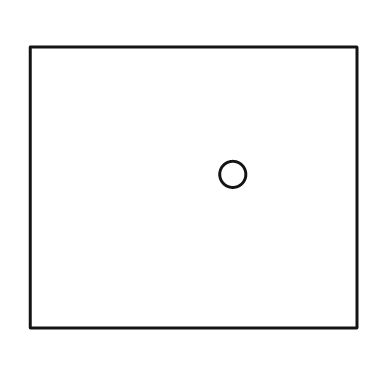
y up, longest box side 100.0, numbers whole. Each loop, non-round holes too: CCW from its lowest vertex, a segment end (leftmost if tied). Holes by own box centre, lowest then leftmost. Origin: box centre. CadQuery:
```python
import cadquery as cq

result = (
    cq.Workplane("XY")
    .moveTo(-50.0, -43.0)
    .lineTo(50.0, -43.0)
    .lineTo(50.0, 43.0)
    .lineTo(-50.0, 43.0)
    .close()
    .moveTo(12.0, 4.0)
    .circle(4.0)
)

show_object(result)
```